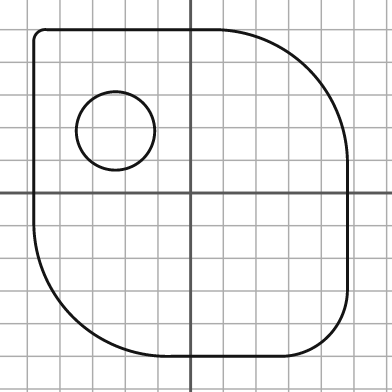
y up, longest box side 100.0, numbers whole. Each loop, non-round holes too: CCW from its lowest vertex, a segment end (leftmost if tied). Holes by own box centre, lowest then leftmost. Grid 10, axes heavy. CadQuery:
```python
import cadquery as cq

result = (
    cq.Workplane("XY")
    .moveTo(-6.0, -50.0)
    .lineTo(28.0, -50.0)
    .threePointArc((42.0, -44.0), (48.0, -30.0))
    .lineTo(48.0, 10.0)
    .threePointArc((36.0, 38.0), (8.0, 50.0))
    .lineTo(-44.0, 50.0)
    .threePointArc((-47.0, 49.0), (-48.0, 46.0))
    .lineTo(-48.0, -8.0)
    .threePointArc((-36.0, -38.0), (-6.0, -50.0))
    .close()
    .moveTo(-23.0, 19.0)
    .circle(12.0)
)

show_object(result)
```